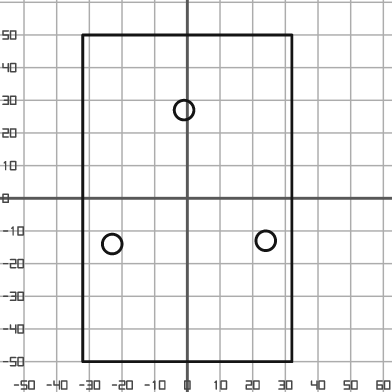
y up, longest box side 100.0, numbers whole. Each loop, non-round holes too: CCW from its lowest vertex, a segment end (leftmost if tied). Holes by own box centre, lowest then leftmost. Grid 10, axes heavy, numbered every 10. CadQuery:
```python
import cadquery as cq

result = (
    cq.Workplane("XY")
    .moveTo(-32.0, -50.0)
    .lineTo(32.0, -50.0)
    .lineTo(32.0, 50.0)
    .lineTo(-32.0, 50.0)
    .close()
    .moveTo(-23.0, -14.0)
    .circle(3.0)
    .moveTo(24.0, -13.0)
    .circle(3.0)
    .moveTo(-1.0, 27.0)
    .circle(3.0)
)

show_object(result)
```